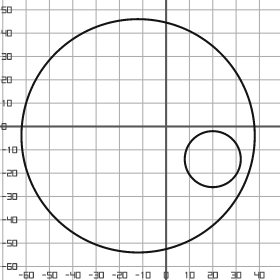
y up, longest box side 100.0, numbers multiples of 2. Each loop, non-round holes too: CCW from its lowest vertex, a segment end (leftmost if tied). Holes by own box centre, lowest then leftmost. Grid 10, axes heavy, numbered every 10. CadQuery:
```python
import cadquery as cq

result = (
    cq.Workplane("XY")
    .moveTo(-12.0, -4.0)
    .circle(50.0)
    .moveTo(20.0, -14.0)
    .circle(12.0)
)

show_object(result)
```